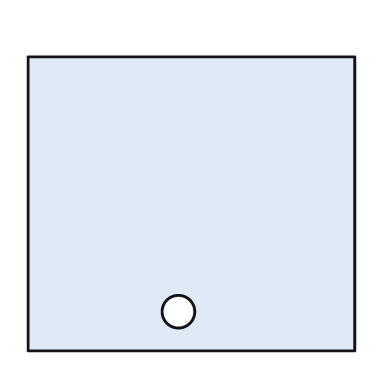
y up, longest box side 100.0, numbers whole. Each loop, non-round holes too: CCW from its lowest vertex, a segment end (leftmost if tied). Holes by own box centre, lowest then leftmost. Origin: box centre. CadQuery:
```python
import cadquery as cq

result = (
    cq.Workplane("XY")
    .moveTo(-50.0, -45.0)
    .lineTo(50.0, -45.0)
    .lineTo(50.0, 45.0)
    .lineTo(-50.0, 45.0)
    .close()
    .moveTo(-4.0, -33.0)
    .circle(5.0)
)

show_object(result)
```